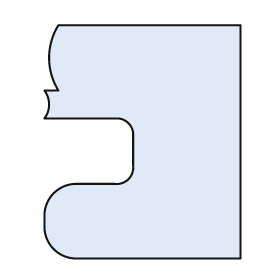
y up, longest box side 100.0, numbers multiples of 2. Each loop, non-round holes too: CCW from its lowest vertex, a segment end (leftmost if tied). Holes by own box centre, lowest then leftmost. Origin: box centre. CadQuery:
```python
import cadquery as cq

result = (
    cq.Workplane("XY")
    .moveTo(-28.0, -50.0)
    .lineTo(42.0, -50.0)
    .lineTo(42.0, 50.0)
    .lineTo(-36.0, 50.0)
    .threePointArc((-40.0, 36.0), (-36.0, 22.0))
    .lineTo(-42.0, 22.0)
    .threePointArc((-40.0, 16.0), (-42.0, 10.0))
    .lineTo(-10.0, 10.0)
    .threePointArc((-6.0, 8.0), (-4.0, 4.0))
    .lineTo(-4.0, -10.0)
    .threePointArc((-6.0, -16.0), (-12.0, -18.0))
    .lineTo(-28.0, -18.0)
    .threePointArc((-38.0, -22.0), (-42.0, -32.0))
    .lineTo(-42.0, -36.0)
    .threePointArc((-38.0, -46.0), (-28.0, -50.0))
    .close()
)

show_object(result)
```